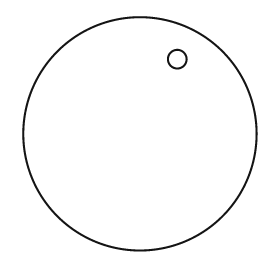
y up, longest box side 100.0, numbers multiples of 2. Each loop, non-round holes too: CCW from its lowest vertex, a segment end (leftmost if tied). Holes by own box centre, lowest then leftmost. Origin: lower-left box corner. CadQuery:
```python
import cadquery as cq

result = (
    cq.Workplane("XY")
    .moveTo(50.0, 50.0)
    .circle(50.0)
    .moveTo(66.0, 82.0)
    .circle(4.0)
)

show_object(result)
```